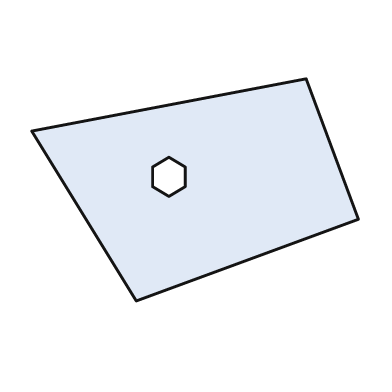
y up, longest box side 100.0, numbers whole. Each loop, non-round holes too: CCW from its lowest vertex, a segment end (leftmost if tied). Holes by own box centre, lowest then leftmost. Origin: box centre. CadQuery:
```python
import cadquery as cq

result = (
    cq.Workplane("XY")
    .moveTo(-18.0, -34.0)
    .lineTo(50.0, -9.0)
    .lineTo(34.0, 34.0)
    .lineTo(-50.0, 18.0)
    .close()
    .moveTo(-8.0, -2.0)
    .lineTo(-3.0, 1.0)
    .lineTo(-3.0, 7.0)
    .lineTo(-8.0, 10.0)
    .lineTo(-13.0, 7.0)
    .lineTo(-13.0, 1.0)
    .close()
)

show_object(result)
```